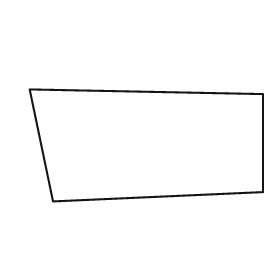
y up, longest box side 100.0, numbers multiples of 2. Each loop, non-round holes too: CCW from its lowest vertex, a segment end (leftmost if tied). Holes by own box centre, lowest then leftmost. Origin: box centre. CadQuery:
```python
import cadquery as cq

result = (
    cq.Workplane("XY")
    .moveTo(-40.0, -24.0)
    .lineTo(50.0, -20.0)
    .lineTo(50.0, 22.0)
    .lineTo(-50.0, 24.0)
    .close()
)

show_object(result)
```